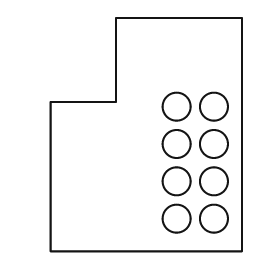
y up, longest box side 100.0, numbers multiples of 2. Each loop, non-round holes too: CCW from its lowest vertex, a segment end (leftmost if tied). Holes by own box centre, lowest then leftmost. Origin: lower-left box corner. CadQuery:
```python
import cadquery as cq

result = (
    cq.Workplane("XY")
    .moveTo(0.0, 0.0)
    .lineTo(82.0, 0.0)
    .lineTo(82.0, 100.0)
    .lineTo(28.0, 100.0)
    .lineTo(28.0, 64.0)
    .lineTo(0.0, 64.0)
    .close()
    .moveTo(54.0, 14.0)
    .circle(6.0)
    .moveTo(70.0, 14.0)
    .circle(6.0)
    .moveTo(54.0, 30.0)
    .circle(6.0)
    .moveTo(70.0, 30.0)
    .circle(6.0)
    .moveTo(54.0, 46.0)
    .circle(6.0)
    .moveTo(70.0, 46.0)
    .circle(6.0)
    .moveTo(54.0, 62.0)
    .circle(6.0)
    .moveTo(70.0, 62.0)
    .circle(6.0)
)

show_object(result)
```